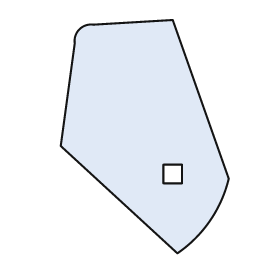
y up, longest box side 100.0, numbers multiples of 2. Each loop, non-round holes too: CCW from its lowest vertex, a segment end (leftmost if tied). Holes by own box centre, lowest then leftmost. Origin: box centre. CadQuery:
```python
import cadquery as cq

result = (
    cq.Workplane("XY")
    .moveTo(14.0, -50.0)
    .threePointArc((28.0, -36.0), (36.0, -18.0))
    .lineTo(12.0, 50.0)
    .lineTo(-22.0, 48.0)
    .threePointArc((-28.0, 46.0), (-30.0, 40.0))
    .lineTo(-36.0, -4.0)
    .close()
    .moveTo(8.0, -20.0)
    .lineTo(16.0, -20.0)
    .lineTo(16.0, -12.0)
    .lineTo(8.0, -12.0)
    .close()
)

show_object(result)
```